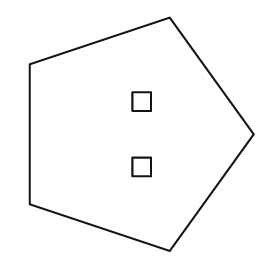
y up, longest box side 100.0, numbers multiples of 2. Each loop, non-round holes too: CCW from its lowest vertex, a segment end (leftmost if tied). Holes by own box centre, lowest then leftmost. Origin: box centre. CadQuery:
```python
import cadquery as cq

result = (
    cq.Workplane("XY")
    .moveTo(12.0, -50.0)
    .lineTo(48.0, 0.0)
    .lineTo(12.0, 50.0)
    .lineTo(-48.0, 30.0)
    .lineTo(-48.0, -30.0)
    .close()
    .moveTo(-4.0, -18.0)
    .lineTo(4.0, -18.0)
    .lineTo(4.0, -10.0)
    .lineTo(-4.0, -10.0)
    .close()
    .moveTo(-4.0, 10.0)
    .lineTo(4.0, 10.0)
    .lineTo(4.0, 18.0)
    .lineTo(-4.0, 18.0)
    .close()
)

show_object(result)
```